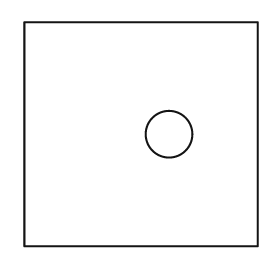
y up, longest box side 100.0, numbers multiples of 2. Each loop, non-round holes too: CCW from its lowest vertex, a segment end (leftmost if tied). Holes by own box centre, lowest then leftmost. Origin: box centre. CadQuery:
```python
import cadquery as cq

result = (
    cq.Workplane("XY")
    .moveTo(-50.0, -48.0)
    .lineTo(50.0, -48.0)
    .lineTo(50.0, 48.0)
    .lineTo(-50.0, 48.0)
    .close()
    .moveTo(12.0, 0.0)
    .circle(10.0)
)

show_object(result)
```